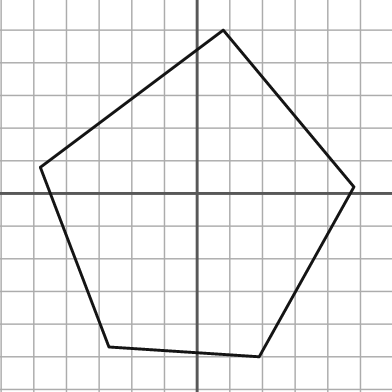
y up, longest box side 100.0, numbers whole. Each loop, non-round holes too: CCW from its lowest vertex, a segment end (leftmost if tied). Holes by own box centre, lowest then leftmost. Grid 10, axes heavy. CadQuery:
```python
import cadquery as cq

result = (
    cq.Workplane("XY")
    .moveTo(19.0, -50.0)
    .lineTo(48.0, 2.0)
    .lineTo(8.0, 50.0)
    .lineTo(-48.0, 8.0)
    .lineTo(-27.0, -47.0)
    .close()
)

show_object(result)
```